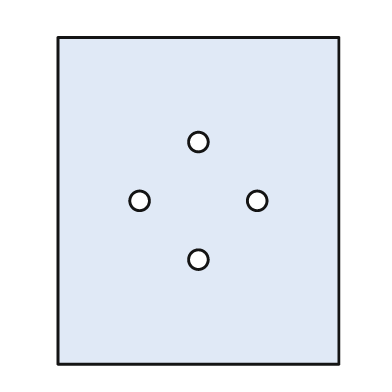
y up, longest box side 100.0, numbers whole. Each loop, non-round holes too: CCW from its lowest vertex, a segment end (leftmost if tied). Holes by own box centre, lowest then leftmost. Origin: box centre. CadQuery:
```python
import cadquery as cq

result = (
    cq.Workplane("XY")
    .moveTo(-43.0, -50.0)
    .lineTo(43.0, -50.0)
    .lineTo(43.0, 50.0)
    .lineTo(-43.0, 50.0)
    .close()
    .moveTo(0.0, -18.0)
    .circle(3.0)
    .moveTo(-18.0, 0.0)
    .circle(3.0)
    .moveTo(18.0, 0.0)
    .circle(3.0)
    .moveTo(0.0, 18.0)
    .circle(3.0)
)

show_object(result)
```